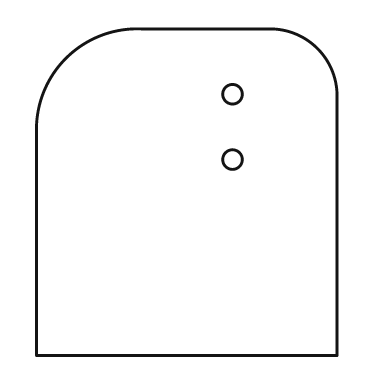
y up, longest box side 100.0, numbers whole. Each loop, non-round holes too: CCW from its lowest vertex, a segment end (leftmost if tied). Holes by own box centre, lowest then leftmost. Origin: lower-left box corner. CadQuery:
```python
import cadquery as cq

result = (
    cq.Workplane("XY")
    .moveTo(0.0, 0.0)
    .lineTo(92.0, 0.0)
    .lineTo(92.0, 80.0)
    .threePointArc((86.0, 94.0), (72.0, 100.0))
    .lineTo(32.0, 100.0)
    .threePointArc((9.0, 91.0), (0.0, 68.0))
    .close()
    .moveTo(60.0, 60.0)
    .circle(3.0)
    .moveTo(60.0, 80.0)
    .circle(3.0)
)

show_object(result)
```